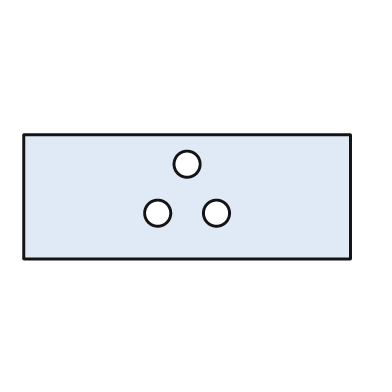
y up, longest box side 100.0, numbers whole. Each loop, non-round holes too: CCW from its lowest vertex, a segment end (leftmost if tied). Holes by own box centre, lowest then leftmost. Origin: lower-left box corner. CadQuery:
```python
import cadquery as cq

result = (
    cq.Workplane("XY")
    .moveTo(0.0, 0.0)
    .lineTo(100.0, 0.0)
    .lineTo(100.0, 38.0)
    .lineTo(0.0, 38.0)
    .close()
    .moveTo(41.0, 14.0)
    .circle(4.0)
    .moveTo(59.0, 14.0)
    .circle(4.0)
    .moveTo(50.0, 29.0)
    .circle(4.0)
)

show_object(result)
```